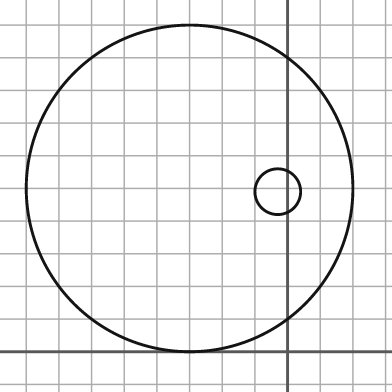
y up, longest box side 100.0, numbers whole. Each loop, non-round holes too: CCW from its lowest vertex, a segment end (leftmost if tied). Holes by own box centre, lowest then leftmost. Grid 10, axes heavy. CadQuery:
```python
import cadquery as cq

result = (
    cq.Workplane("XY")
    .moveTo(-30.0, 50.0)
    .circle(50.0)
    .moveTo(-3.0, 49.0)
    .circle(7.0)
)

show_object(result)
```